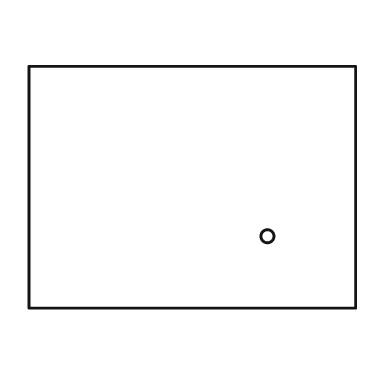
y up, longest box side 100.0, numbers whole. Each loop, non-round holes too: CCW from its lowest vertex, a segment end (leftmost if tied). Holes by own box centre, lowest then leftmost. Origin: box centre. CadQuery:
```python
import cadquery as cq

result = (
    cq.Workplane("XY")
    .moveTo(-50.0, -37.0)
    .lineTo(50.0, -37.0)
    .lineTo(50.0, 37.0)
    .lineTo(-50.0, 37.0)
    .close()
    .moveTo(23.0, -15.0)
    .circle(2.0)
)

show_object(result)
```